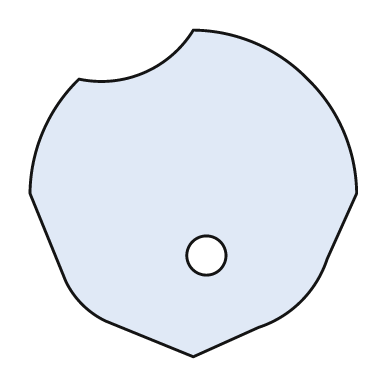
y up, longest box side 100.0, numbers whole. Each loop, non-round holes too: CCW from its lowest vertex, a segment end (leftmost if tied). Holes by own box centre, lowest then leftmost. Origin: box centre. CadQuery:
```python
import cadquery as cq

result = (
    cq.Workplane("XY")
    .moveTo(0.0, -50.0)
    .lineTo(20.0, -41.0)
    .threePointArc((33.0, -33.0), (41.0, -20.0))
    .lineTo(50.0, 0.0)
    .threePointArc((46.0, 19.0), (35.0, 35.0))
    .threePointArc((19.0, 46.0), (0.0, 50.0))
    .threePointArc((-15.0, 37.0), (-35.0, 35.0))
    .threePointArc((-46.0, 19.0), (-50.0, 0.0))
    .lineTo(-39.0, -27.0)
    .threePointArc((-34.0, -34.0), (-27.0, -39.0))
    .close()
    .moveTo(4.0, -19.0)
    .circle(6.0)
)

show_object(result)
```